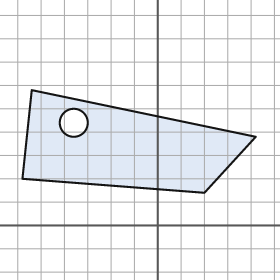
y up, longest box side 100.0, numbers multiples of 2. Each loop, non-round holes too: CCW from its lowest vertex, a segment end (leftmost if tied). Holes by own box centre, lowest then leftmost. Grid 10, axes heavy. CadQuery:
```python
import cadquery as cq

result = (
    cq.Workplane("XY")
    .moveTo(20.0, 14.0)
    .lineTo(42.0, 38.0)
    .lineTo(-54.0, 58.0)
    .lineTo(-58.0, 20.0)
    .close()
    .moveTo(-36.0, 44.0)
    .circle(6.0)
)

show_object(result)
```